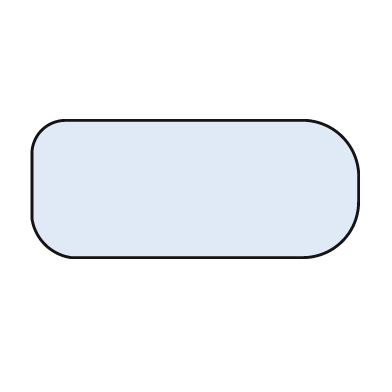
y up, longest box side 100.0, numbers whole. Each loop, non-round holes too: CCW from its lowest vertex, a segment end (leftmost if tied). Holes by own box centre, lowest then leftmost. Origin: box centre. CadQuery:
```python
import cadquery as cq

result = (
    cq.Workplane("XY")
    .moveTo(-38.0, -21.0)
    .lineTo(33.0, -21.0)
    .threePointArc((45.0, -16.0), (50.0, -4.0))
    .lineTo(50.0, 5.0)
    .threePointArc((45.0, 16.0), (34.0, 21.0))
    .lineTo(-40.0, 21.0)
    .threePointArc((-47.0, 18.0), (-50.0, 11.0))
    .lineTo(-50.0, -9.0)
    .threePointArc((-46.0, -17.0), (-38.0, -21.0))
    .close()
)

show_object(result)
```